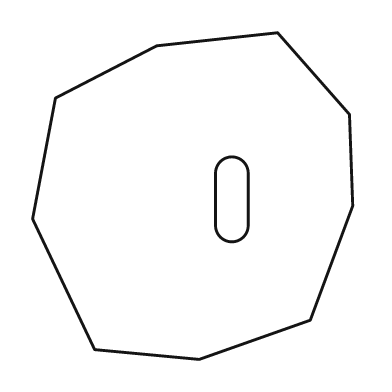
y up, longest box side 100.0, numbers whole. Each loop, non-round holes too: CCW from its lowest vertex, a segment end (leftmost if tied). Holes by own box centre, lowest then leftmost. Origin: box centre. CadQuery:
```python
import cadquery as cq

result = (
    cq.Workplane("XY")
    .moveTo(2.0, -50.0)
    .lineTo(36.0, -38.0)
    .lineTo(49.0, -3.0)
    .lineTo(48.0, 25.0)
    .lineTo(26.0, 50.0)
    .lineTo(-11.0, 46.0)
    .lineTo(-42.0, 30.0)
    .lineTo(-49.0, -7.0)
    .lineTo(-30.0, -47.0)
    .close()
    .moveTo(7.0, -9.0)
    .threePointArc((12.0, -14.0), (17.0, -9.0))
    .lineTo(17.0, 7.0)
    .threePointArc((12.0, 12.0), (7.0, 7.0))
    .close()
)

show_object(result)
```